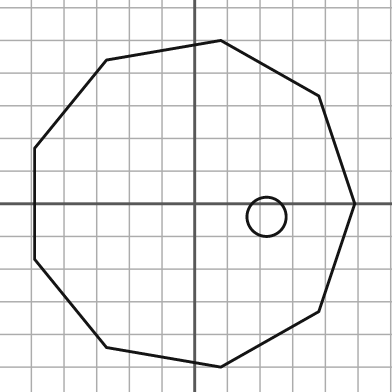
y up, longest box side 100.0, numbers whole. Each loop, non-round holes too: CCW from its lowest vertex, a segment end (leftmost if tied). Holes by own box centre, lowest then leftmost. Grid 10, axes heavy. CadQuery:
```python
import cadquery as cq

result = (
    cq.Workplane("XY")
    .moveTo(8.0, -50.0)
    .lineTo(38.0, -33.0)
    .lineTo(49.0, 0.0)
    .lineTo(38.0, 33.0)
    .lineTo(8.0, 50.0)
    .lineTo(-27.0, 44.0)
    .lineTo(-49.0, 17.0)
    .lineTo(-49.0, -17.0)
    .lineTo(-27.0, -44.0)
    .close()
    .moveTo(22.0, -4.0)
    .circle(6.0)
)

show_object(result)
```